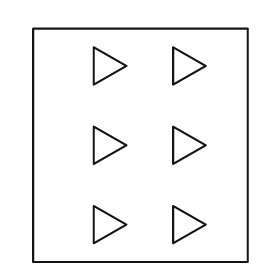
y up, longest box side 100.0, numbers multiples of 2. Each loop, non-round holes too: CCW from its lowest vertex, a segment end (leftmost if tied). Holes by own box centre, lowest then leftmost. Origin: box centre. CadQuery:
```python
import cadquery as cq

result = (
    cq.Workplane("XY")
    .moveTo(-46.0, -50.0)
    .lineTo(46.0, -50.0)
    .lineTo(46.0, 50.0)
    .lineTo(-46.0, 50.0)
    .close()
    .moveTo(-20.0, -42.0)
    .lineTo(-6.0, -34.0)
    .lineTo(-20.0, -26.0)
    .close()
    .moveTo(14.0, -42.0)
    .lineTo(28.0, -34.0)
    .lineTo(14.0, -26.0)
    .close()
    .moveTo(-20.0, -8.0)
    .lineTo(-6.0, 0.0)
    .lineTo(-20.0, 8.0)
    .close()
    .moveTo(14.0, -8.0)
    .lineTo(28.0, 0.0)
    .lineTo(14.0, 8.0)
    .close()
    .moveTo(-20.0, 26.0)
    .lineTo(-6.0, 34.0)
    .lineTo(-20.0, 42.0)
    .close()
    .moveTo(14.0, 26.0)
    .lineTo(28.0, 34.0)
    .lineTo(14.0, 42.0)
    .close()
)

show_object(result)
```